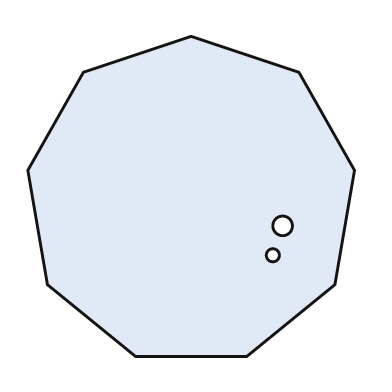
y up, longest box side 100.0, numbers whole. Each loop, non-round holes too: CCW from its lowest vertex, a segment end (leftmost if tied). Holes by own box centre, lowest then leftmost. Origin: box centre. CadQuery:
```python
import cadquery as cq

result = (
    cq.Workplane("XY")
    .moveTo(-17.0, -49.0)
    .lineTo(17.0, -49.0)
    .lineTo(44.0, -27.0)
    .lineTo(50.0, 8.0)
    .lineTo(33.0, 38.0)
    .lineTo(0.0, 49.0)
    .lineTo(-33.0, 38.0)
    .lineTo(-50.0, 8.0)
    .lineTo(-44.0, -27.0)
    .close()
    .moveTo(25.0, -18.0)
    .circle(2.0)
    .moveTo(28.0, -9.0)
    .circle(3.0)
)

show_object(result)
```